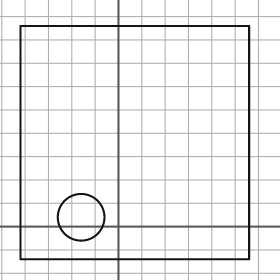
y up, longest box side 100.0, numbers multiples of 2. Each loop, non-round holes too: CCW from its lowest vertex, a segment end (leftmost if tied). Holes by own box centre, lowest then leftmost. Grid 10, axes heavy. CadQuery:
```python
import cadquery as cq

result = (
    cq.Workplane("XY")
    .moveTo(-42.0, -14.0)
    .lineTo(56.0, -14.0)
    .lineTo(56.0, 86.0)
    .lineTo(-42.0, 86.0)
    .close()
    .moveTo(-16.0, 4.0)
    .circle(10.0)
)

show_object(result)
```